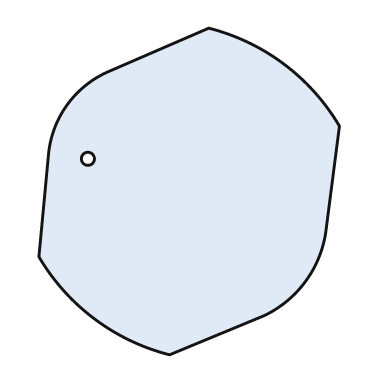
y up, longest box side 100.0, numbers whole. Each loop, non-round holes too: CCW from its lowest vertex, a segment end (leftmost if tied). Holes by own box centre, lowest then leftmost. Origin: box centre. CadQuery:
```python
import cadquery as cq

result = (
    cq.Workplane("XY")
    .moveTo(-6.0, -50.0)
    .lineTo(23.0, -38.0)
    .threePointArc((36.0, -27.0), (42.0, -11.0))
    .lineTo(46.0, 20.0)
    .threePointArc((29.0, 39.0), (6.0, 50.0))
    .lineTo(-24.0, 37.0)
    .threePointArc((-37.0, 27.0), (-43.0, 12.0))
    .lineTo(-46.0, -20.0)
    .threePointArc((-29.0, -39.0), (-6.0, -50.0))
    .close()
    .moveTo(-31.0, 10.0)
    .circle(2.0)
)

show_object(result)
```